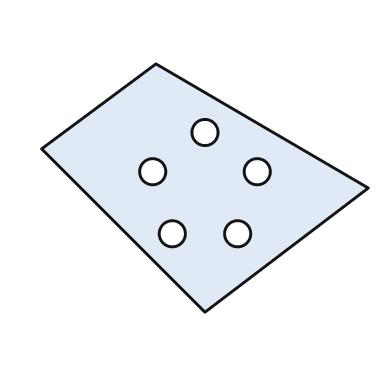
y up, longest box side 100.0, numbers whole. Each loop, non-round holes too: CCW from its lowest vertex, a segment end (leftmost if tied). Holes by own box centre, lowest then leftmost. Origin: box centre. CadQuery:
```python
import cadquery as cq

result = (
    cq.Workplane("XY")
    .moveTo(0.0, -38.0)
    .lineTo(50.0, 0.0)
    .lineTo(-15.0, 38.0)
    .lineTo(-50.0, 12.0)
    .close()
    .moveTo(-10.0, -14.0)
    .circle(4.0)
    .moveTo(10.0, -14.0)
    .circle(4.0)
    .moveTo(-16.0, 5.0)
    .circle(4.0)
    .moveTo(16.0, 5.0)
    .circle(4.0)
    .moveTo(0.0, 17.0)
    .circle(4.0)
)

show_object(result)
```